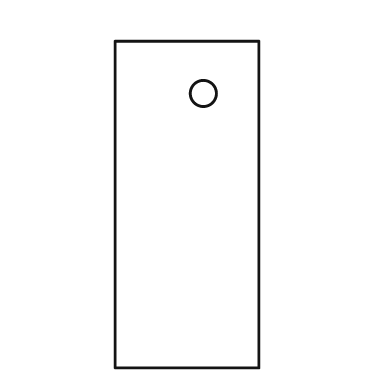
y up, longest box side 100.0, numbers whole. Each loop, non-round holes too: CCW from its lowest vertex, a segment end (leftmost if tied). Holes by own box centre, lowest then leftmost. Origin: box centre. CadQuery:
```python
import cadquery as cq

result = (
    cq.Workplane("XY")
    .moveTo(-22.0, -50.0)
    .lineTo(22.0, -50.0)
    .lineTo(22.0, 50.0)
    .lineTo(-22.0, 50.0)
    .close()
    .moveTo(5.0, 34.0)
    .circle(4.0)
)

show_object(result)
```